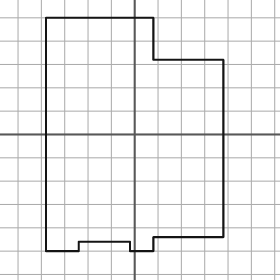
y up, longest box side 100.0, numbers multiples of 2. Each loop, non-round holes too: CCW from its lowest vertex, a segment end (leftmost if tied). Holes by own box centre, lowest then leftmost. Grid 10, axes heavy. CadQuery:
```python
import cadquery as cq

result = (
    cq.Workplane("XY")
    .moveTo(-38.0, -50.0)
    .lineTo(-24.0, -50.0)
    .lineTo(-24.0, -46.0)
    .lineTo(-2.0, -46.0)
    .lineTo(-2.0, -50.0)
    .lineTo(8.0, -50.0)
    .lineTo(8.0, -44.0)
    .lineTo(38.0, -44.0)
    .lineTo(38.0, 32.0)
    .lineTo(8.0, 32.0)
    .lineTo(8.0, 50.0)
    .lineTo(-38.0, 50.0)
    .close()
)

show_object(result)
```